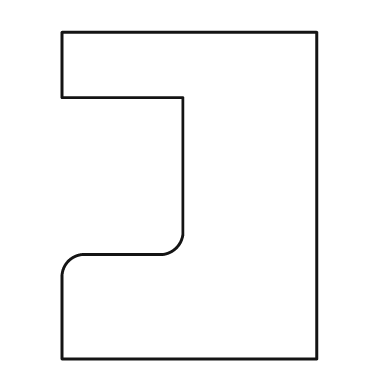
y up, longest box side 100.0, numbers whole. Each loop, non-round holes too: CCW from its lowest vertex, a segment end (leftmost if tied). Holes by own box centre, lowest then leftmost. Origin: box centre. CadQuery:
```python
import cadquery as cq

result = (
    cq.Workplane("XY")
    .moveTo(-39.0, -50.0)
    .lineTo(39.0, -50.0)
    .lineTo(39.0, 50.0)
    .lineTo(-39.0, 50.0)
    .lineTo(-39.0, 30.0)
    .lineTo(-2.0, 30.0)
    .lineTo(-2.0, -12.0)
    .threePointArc((-4.0, -16.0), (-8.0, -18.0))
    .lineTo(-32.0, -18.0)
    .threePointArc((-37.0, -20.0), (-39.0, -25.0))
    .close()
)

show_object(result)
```